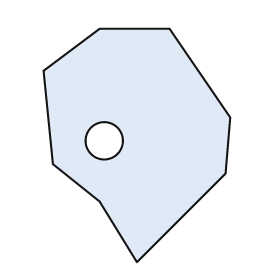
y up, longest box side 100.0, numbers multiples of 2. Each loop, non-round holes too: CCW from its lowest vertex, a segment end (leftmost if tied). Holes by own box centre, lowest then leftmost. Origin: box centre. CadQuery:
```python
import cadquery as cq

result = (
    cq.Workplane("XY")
    .moveTo(0.0, -50.0)
    .lineTo(38.0, -12.0)
    .lineTo(40.0, 12.0)
    .lineTo(14.0, 50.0)
    .lineTo(-16.0, 50.0)
    .lineTo(-40.0, 32.0)
    .lineTo(-36.0, -8.0)
    .lineTo(-16.0, -24.0)
    .close()
    .moveTo(-14.0, 2.0)
    .circle(8.0)
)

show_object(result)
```